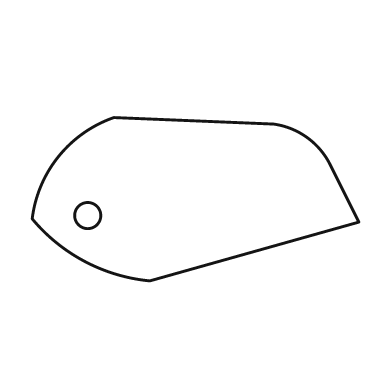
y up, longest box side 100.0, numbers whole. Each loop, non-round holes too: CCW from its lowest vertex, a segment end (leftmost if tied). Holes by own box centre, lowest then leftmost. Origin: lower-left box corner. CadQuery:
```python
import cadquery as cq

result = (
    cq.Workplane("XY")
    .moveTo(36.0, 0.0)
    .lineTo(100.0, 18.0)
    .lineTo(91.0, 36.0)
    .threePointArc((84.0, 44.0), (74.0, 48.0))
    .lineTo(25.0, 50.0)
    .threePointArc((8.0, 38.0), (0.0, 19.0))
    .threePointArc((16.0, 6.0), (36.0, 0.0))
    .close()
    .moveTo(17.0, 20.0)
    .circle(4.0)
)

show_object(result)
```